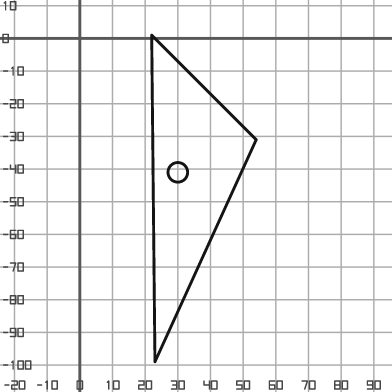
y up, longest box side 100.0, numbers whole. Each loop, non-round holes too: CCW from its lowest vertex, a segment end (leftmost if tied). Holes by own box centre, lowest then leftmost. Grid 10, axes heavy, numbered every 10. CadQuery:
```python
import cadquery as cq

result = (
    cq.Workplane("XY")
    .moveTo(23.0, -99.0)
    .lineTo(54.0, -31.0)
    .lineTo(22.0, 1.0)
    .close()
    .moveTo(30.0, -41.0)
    .circle(3.0)
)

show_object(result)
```